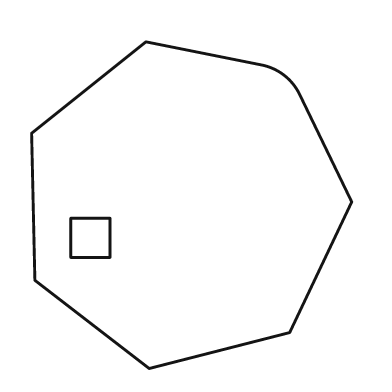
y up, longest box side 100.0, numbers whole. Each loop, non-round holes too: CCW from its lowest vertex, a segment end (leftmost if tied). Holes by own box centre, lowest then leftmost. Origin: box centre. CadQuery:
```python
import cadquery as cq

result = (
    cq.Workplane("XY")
    .moveTo(-13.0, -50.0)
    .lineTo(30.0, -39.0)
    .lineTo(49.0, 1.0)
    .lineTo(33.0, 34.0)
    .threePointArc((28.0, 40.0), (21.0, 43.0))
    .lineTo(-14.0, 50.0)
    .lineTo(-49.0, 22.0)
    .lineTo(-48.0, -23.0)
    .close()
    .moveTo(-37.0, -16.0)
    .lineTo(-25.0, -16.0)
    .lineTo(-25.0, -4.0)
    .lineTo(-37.0, -4.0)
    .close()
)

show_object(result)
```